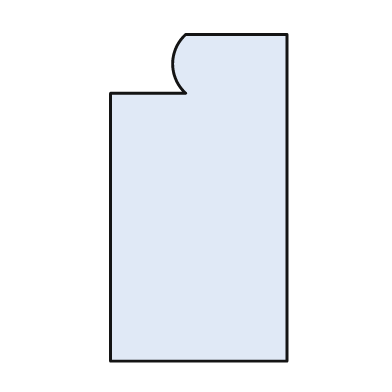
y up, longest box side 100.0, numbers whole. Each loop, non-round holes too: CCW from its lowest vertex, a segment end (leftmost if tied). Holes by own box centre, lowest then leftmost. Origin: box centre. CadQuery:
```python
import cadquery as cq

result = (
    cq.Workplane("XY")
    .moveTo(-27.0, -50.0)
    .lineTo(27.0, -50.0)
    .lineTo(27.0, 50.0)
    .lineTo(-4.0, 50.0)
    .threePointArc((-8.0, 41.0), (-4.0, 32.0))
    .lineTo(-27.0, 32.0)
    .close()
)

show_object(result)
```